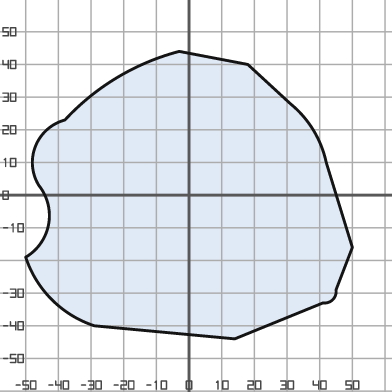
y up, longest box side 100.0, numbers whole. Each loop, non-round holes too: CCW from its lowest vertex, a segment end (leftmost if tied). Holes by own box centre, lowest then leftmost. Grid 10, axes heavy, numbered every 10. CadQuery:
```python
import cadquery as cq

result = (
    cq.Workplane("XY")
    .moveTo(14.0, -44.0)
    .lineTo(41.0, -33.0)
    .threePointArc((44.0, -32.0), (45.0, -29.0))
    .lineTo(50.0, -16.0)
    .lineTo(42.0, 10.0)
    .threePointArc((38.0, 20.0), (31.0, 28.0))
    .lineTo(18.0, 40.0)
    .lineTo(-3.0, 44.0)
    .threePointArc((-22.0, 36.0), (-38.0, 23.0))
    .threePointArc((-47.0, 15.0), (-46.0, 3.0))
    .threePointArc((-43.0, -9.0), (-50.0, -19.0))
    .threePointArc((-42.0, -32.0), (-29.0, -40.0))
    .close()
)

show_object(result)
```